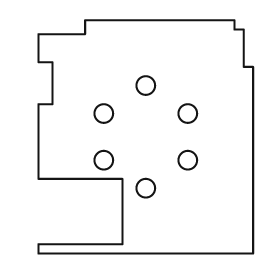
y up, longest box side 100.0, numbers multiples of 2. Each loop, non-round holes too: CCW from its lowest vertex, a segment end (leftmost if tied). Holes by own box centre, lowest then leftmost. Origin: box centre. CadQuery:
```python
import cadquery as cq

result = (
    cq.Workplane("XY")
    .moveTo(-46.0, -50.0)
    .lineTo(46.0, -50.0)
    .lineTo(46.0, 30.0)
    .lineTo(42.0, 30.0)
    .lineTo(42.0, 46.0)
    .lineTo(38.0, 46.0)
    .lineTo(38.0, 50.0)
    .lineTo(-26.0, 50.0)
    .lineTo(-26.0, 44.0)
    .lineTo(-46.0, 44.0)
    .lineTo(-46.0, 32.0)
    .lineTo(-40.0, 32.0)
    .lineTo(-40.0, 14.0)
    .lineTo(-46.0, 14.0)
    .lineTo(-46.0, -18.0)
    .lineTo(-10.0, -18.0)
    .lineTo(-10.0, -46.0)
    .lineTo(-46.0, -46.0)
    .close()
    .moveTo(0.0, -22.0)
    .circle(4.0)
    .moveTo(-18.0, -10.0)
    .circle(4.0)
    .moveTo(18.0, -10.0)
    .circle(4.0)
    .moveTo(-18.0, 10.0)
    .circle(4.0)
    .moveTo(18.0, 10.0)
    .circle(4.0)
    .moveTo(0.0, 22.0)
    .circle(4.0)
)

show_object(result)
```